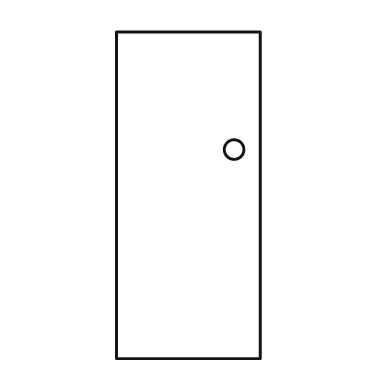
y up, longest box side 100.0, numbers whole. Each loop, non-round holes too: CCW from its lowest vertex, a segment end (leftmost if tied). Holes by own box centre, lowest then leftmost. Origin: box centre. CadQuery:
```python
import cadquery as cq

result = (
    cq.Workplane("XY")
    .moveTo(-22.0, -50.0)
    .lineTo(22.0, -50.0)
    .lineTo(22.0, 50.0)
    .lineTo(-22.0, 50.0)
    .close()
    .moveTo(14.0, 14.0)
    .circle(3.0)
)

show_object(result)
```